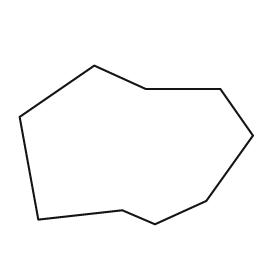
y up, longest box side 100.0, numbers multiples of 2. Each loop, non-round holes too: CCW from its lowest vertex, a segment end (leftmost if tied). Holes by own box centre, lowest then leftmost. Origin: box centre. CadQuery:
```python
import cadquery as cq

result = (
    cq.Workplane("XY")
    .moveTo(8.0, -34.0)
    .lineTo(30.0, -24.0)
    .lineTo(50.0, 4.0)
    .lineTo(36.0, 24.0)
    .lineTo(4.0, 24.0)
    .lineTo(-18.0, 34.0)
    .lineTo(-50.0, 12.0)
    .lineTo(-42.0, -32.0)
    .lineTo(-6.0, -28.0)
    .close()
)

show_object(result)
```